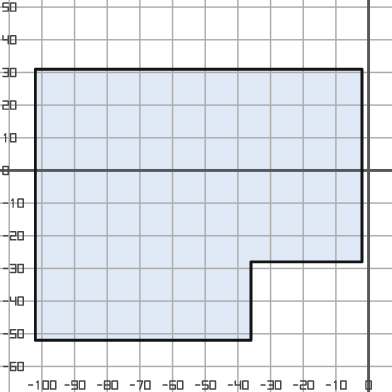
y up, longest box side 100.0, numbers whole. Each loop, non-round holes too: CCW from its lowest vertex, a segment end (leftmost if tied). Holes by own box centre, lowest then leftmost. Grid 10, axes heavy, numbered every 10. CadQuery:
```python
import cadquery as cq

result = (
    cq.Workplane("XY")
    .moveTo(-102.0, -52.0)
    .lineTo(-36.0, -52.0)
    .lineTo(-36.0, -28.0)
    .lineTo(-2.0, -28.0)
    .lineTo(-2.0, 31.0)
    .lineTo(-102.0, 31.0)
    .close()
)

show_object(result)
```